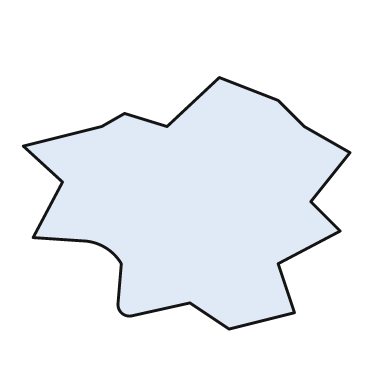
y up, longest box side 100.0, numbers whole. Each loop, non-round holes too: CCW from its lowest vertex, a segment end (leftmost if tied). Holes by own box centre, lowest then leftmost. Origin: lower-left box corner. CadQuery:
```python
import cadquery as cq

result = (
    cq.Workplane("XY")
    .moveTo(63.0, 0.0)
    .lineTo(83.0, 5.0)
    .lineTo(78.0, 20.0)
    .lineTo(97.0, 30.0)
    .lineTo(88.0, 39.0)
    .lineTo(100.0, 54.0)
    .lineTo(86.0, 62.0)
    .lineTo(78.0, 70.0)
    .lineTo(60.0, 77.0)
    .lineTo(44.0, 62.0)
    .lineTo(31.0, 66.0)
    .lineTo(24.0, 62.0)
    .lineTo(0.0, 56.0)
    .lineTo(12.0, 45.0)
    .lineTo(3.0, 28.0)
    .lineTo(18.0, 27.0)
    .threePointArc((25.0, 25.0), (30.0, 20.0))
    .lineTo(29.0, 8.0)
    .threePointArc((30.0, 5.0), (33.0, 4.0))
    .lineTo(51.0, 8.0)
    .close()
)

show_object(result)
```